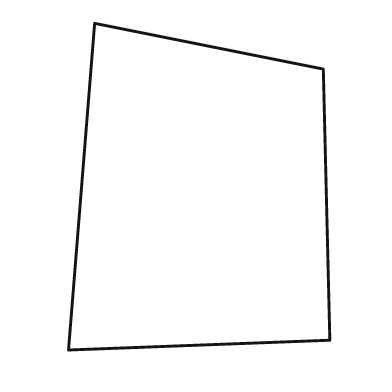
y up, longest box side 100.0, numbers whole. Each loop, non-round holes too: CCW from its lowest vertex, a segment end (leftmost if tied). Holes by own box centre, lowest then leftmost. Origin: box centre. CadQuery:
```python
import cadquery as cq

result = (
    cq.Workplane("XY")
    .moveTo(-40.0, -50.0)
    .lineTo(40.0, -47.0)
    .lineTo(38.0, 36.0)
    .lineTo(-32.0, 50.0)
    .close()
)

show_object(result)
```